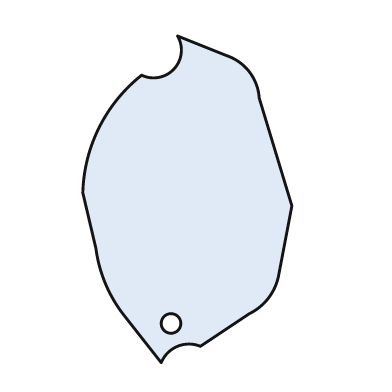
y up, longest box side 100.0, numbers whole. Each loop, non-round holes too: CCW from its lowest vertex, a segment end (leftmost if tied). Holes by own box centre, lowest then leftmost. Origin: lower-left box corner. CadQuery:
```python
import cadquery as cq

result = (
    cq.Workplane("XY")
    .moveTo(24.0, 0.0)
    .threePointArc((29.0, 5.0), (36.0, 5.0))
    .lineTo(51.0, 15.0)
    .threePointArc((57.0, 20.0), (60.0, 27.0))
    .lineTo(64.0, 48.0)
    .lineTo(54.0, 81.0)
    .threePointArc((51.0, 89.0), (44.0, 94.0))
    .lineTo(29.0, 100.0)
    .threePointArc((28.0, 90.0), (18.0, 88.0))
    .threePointArc((5.0, 72.0), (0.0, 52.0))
    .lineTo(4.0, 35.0)
    .threePointArc((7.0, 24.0), (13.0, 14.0))
    .close()
    .moveTo(27.0, 12.0)
    .circle(3.0)
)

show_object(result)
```